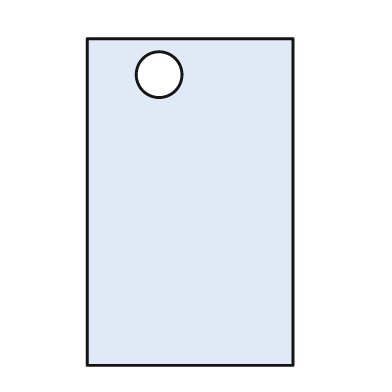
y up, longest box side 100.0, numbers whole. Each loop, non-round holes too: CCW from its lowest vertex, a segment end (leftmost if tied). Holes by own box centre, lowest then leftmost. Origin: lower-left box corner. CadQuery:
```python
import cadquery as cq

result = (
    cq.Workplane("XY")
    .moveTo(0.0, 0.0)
    .lineTo(63.0, 0.0)
    .lineTo(63.0, 100.0)
    .lineTo(0.0, 100.0)
    .close()
    .moveTo(22.0, 89.0)
    .circle(7.0)
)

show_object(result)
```